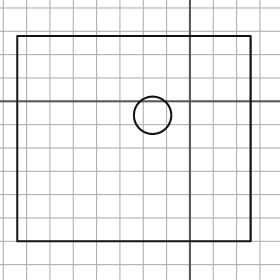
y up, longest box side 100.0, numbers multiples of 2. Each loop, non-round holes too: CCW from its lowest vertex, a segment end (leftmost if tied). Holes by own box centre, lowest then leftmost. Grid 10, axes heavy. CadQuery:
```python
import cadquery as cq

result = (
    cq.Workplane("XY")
    .moveTo(-74.0, -60.0)
    .lineTo(26.0, -60.0)
    .lineTo(26.0, 28.0)
    .lineTo(-74.0, 28.0)
    .close()
    .moveTo(-16.0, -6.0)
    .circle(8.0)
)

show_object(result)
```